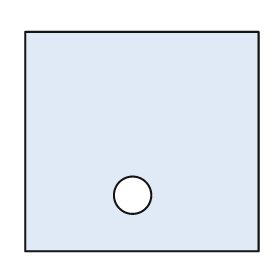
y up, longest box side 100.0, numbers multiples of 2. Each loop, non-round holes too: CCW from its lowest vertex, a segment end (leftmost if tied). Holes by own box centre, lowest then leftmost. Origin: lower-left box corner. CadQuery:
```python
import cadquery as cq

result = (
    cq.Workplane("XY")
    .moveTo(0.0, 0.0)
    .lineTo(100.0, 0.0)
    .lineTo(100.0, 94.0)
    .lineTo(0.0, 94.0)
    .close()
    .moveTo(46.0, 24.0)
    .circle(8.0)
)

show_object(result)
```